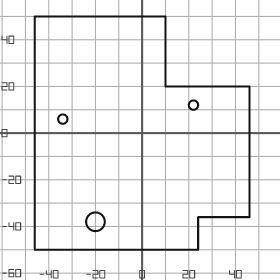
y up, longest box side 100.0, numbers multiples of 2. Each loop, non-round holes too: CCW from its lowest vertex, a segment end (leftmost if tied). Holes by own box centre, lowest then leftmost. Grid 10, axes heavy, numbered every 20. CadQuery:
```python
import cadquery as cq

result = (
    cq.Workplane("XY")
    .moveTo(-46.0, -50.0)
    .lineTo(24.0, -50.0)
    .lineTo(24.0, -36.0)
    .lineTo(46.0, -36.0)
    .lineTo(46.0, 20.0)
    .lineTo(10.0, 20.0)
    .lineTo(10.0, 50.0)
    .lineTo(-46.0, 50.0)
    .close()
    .moveTo(-20.0, -38.0)
    .circle(4.0)
    .moveTo(-34.0, 6.0)
    .circle(2.0)
    .moveTo(22.0, 12.0)
    .circle(2.0)
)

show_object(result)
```